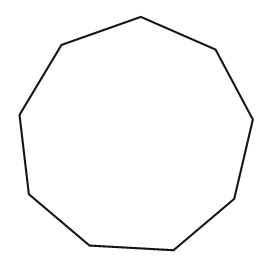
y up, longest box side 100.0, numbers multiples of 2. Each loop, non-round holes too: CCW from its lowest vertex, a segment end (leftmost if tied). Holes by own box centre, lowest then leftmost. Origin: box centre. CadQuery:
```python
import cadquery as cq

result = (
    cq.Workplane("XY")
    .moveTo(16.0, -50.0)
    .lineTo(42.0, -28.0)
    .lineTo(50.0, 6.0)
    .lineTo(34.0, 36.0)
    .lineTo(2.0, 50.0)
    .lineTo(-32.0, 38.0)
    .lineTo(-50.0, 8.0)
    .lineTo(-46.0, -26.0)
    .lineTo(-20.0, -48.0)
    .close()
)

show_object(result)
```